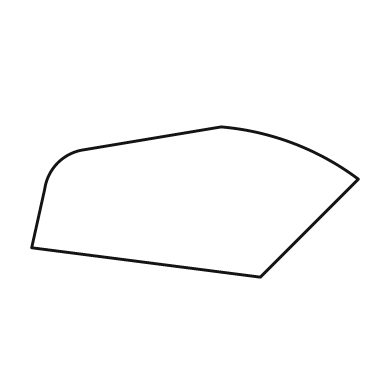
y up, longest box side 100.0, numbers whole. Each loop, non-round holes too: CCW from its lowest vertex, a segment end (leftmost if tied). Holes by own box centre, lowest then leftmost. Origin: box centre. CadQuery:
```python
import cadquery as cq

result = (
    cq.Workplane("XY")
    .moveTo(20.0, -23.0)
    .lineTo(50.0, 7.0)
    .threePointArc((30.0, 18.0), (8.0, 23.0))
    .lineTo(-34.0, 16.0)
    .threePointArc((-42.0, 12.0), (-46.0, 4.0))
    .lineTo(-50.0, -14.0)
    .close()
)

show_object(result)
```